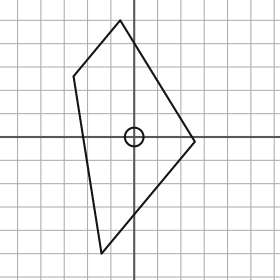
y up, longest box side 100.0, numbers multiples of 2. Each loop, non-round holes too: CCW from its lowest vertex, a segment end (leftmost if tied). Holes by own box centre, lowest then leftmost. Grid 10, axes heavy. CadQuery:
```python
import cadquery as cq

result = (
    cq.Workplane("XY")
    .moveTo(-14.0, -50.0)
    .lineTo(26.0, -2.0)
    .lineTo(-6.0, 50.0)
    .lineTo(-26.0, 26.0)
    .close()
    .moveTo(0.0, 0.0)
    .circle(4.0)
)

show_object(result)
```